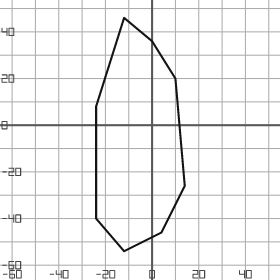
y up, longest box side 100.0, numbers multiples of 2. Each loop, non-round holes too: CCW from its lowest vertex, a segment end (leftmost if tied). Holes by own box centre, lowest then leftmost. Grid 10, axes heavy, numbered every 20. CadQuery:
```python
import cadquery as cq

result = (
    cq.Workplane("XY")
    .moveTo(-12.0, -54.0)
    .lineTo(4.0, -46.0)
    .lineTo(14.0, -26.0)
    .lineTo(10.0, 20.0)
    .lineTo(0.0, 36.0)
    .lineTo(-12.0, 46.0)
    .lineTo(-24.0, 8.0)
    .lineTo(-24.0, -40.0)
    .close()
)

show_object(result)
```